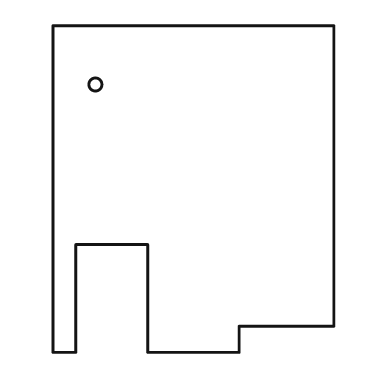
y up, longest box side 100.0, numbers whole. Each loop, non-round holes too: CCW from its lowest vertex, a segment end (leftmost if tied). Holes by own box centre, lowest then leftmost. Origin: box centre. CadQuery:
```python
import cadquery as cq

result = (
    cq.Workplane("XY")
    .moveTo(-43.0, -50.0)
    .lineTo(-36.0, -50.0)
    .lineTo(-36.0, -17.0)
    .lineTo(-14.0, -17.0)
    .lineTo(-14.0, -50.0)
    .lineTo(14.0, -50.0)
    .lineTo(14.0, -42.0)
    .lineTo(43.0, -42.0)
    .lineTo(43.0, 50.0)
    .lineTo(-43.0, 50.0)
    .close()
    .moveTo(-30.0, 32.0)
    .circle(2.0)
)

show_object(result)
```